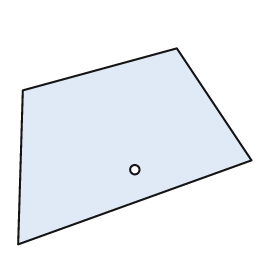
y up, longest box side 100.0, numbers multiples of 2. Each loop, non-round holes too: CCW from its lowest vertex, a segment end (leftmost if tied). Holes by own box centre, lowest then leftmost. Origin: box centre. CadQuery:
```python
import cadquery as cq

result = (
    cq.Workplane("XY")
    .moveTo(-50.0, -42.0)
    .lineTo(50.0, -6.0)
    .lineTo(18.0, 42.0)
    .lineTo(-48.0, 24.0)
    .close()
    .moveTo(0.0, -10.0)
    .circle(2.0)
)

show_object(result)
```